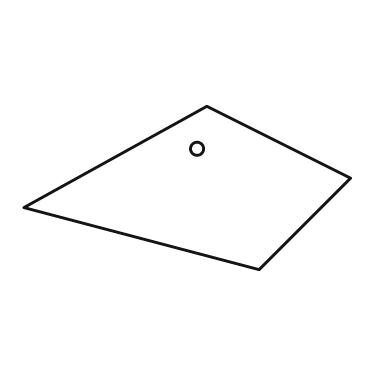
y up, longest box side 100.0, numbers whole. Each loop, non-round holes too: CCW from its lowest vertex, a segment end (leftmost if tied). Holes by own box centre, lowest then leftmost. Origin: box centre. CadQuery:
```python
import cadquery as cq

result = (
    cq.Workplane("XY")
    .moveTo(22.0, -25.0)
    .lineTo(50.0, 3.0)
    .lineTo(6.0, 25.0)
    .lineTo(-50.0, -6.0)
    .close()
    .moveTo(3.0, 12.0)
    .circle(2.0)
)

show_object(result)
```